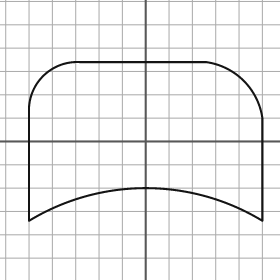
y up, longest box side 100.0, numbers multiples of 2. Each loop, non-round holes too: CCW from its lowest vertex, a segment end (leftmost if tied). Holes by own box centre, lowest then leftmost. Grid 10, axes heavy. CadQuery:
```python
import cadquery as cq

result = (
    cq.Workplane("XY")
    .moveTo(-50.0, -34.0)
    .threePointArc((0.0, -20.0), (50.0, -34.0))
    .lineTo(50.0, 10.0)
    .threePointArc((42.0, 26.0), (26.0, 34.0))
    .lineTo(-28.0, 34.0)
    .threePointArc((-44.0, 28.0), (-50.0, 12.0))
    .close()
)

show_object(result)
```